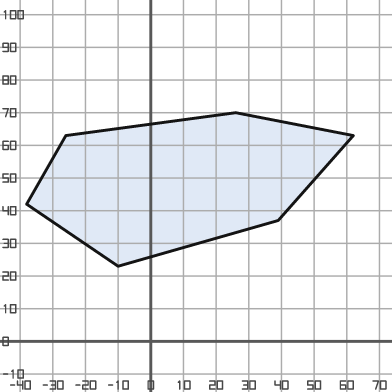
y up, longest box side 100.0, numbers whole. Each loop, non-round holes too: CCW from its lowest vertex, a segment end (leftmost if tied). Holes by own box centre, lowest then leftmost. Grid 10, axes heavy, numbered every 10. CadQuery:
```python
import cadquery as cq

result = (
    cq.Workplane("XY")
    .moveTo(-10.0, 23.0)
    .lineTo(39.0, 37.0)
    .lineTo(62.0, 63.0)
    .lineTo(26.0, 70.0)
    .lineTo(-26.0, 63.0)
    .lineTo(-38.0, 42.0)
    .close()
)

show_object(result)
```